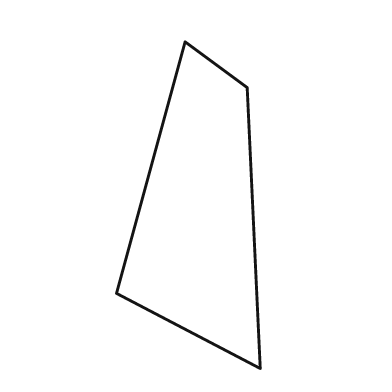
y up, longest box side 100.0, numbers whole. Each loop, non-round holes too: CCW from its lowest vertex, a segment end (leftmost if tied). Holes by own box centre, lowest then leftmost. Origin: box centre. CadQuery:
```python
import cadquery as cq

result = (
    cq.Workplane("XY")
    .moveTo(22.0, -50.0)
    .lineTo(18.0, 36.0)
    .lineTo(-1.0, 50.0)
    .lineTo(-22.0, -27.0)
    .close()
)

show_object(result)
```